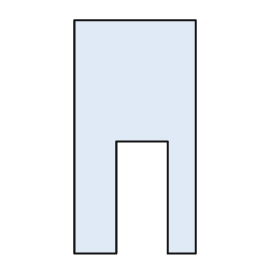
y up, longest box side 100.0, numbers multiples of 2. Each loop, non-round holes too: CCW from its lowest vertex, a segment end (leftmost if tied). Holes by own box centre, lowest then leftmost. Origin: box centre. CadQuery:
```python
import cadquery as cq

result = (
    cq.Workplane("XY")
    .moveTo(-26.0, -50.0)
    .lineTo(-8.0, -50.0)
    .lineTo(-8.0, -2.0)
    .lineTo(14.0, -2.0)
    .lineTo(14.0, -50.0)
    .lineTo(26.0, -50.0)
    .lineTo(26.0, 50.0)
    .lineTo(-26.0, 50.0)
    .close()
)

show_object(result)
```